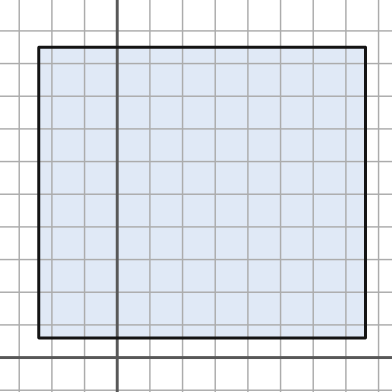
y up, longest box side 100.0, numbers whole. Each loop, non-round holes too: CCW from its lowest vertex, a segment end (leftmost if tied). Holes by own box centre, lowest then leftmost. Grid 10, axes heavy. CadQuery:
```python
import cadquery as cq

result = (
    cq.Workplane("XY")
    .moveTo(-24.0, 6.0)
    .lineTo(76.0, 6.0)
    .lineTo(76.0, 95.0)
    .lineTo(-24.0, 95.0)
    .close()
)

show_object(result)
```